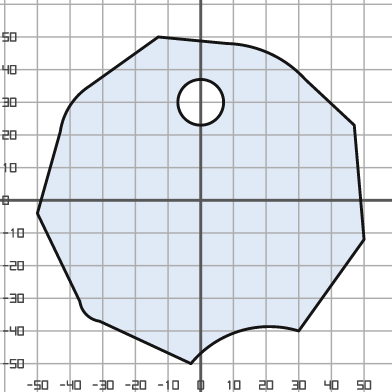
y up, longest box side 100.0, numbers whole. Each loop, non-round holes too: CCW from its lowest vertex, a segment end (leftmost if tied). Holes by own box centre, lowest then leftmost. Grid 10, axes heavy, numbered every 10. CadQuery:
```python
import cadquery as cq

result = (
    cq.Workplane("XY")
    .moveTo(-3.0, -50.0)
    .threePointArc((12.0, -40.0), (30.0, -40.0))
    .lineTo(50.0, -12.0)
    .lineTo(47.0, 23.0)
    .lineTo(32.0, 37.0)
    .threePointArc((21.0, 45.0), (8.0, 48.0))
    .lineTo(-13.0, 50.0)
    .lineTo(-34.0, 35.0)
    .threePointArc((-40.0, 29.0), (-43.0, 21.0))
    .lineTo(-50.0, -4.0)
    .lineTo(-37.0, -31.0)
    .threePointArc((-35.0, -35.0), (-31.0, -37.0))
    .close()
    .moveTo(0.0, 30.0)
    .circle(7.0)
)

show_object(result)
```